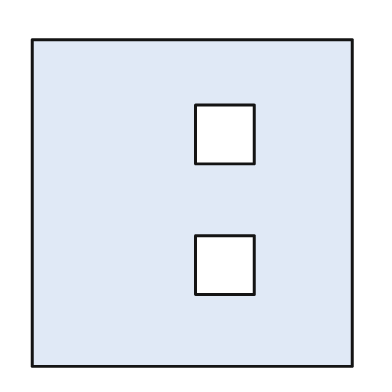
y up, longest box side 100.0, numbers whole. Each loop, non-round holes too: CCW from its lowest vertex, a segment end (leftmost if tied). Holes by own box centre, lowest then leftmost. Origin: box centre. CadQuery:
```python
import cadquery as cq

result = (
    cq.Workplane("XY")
    .moveTo(-49.0, -50.0)
    .lineTo(49.0, -50.0)
    .lineTo(49.0, 50.0)
    .lineTo(-49.0, 50.0)
    .close()
    .moveTo(1.0, -28.0)
    .lineTo(19.0, -28.0)
    .lineTo(19.0, -10.0)
    .lineTo(1.0, -10.0)
    .close()
    .moveTo(1.0, 12.0)
    .lineTo(19.0, 12.0)
    .lineTo(19.0, 30.0)
    .lineTo(1.0, 30.0)
    .close()
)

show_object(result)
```